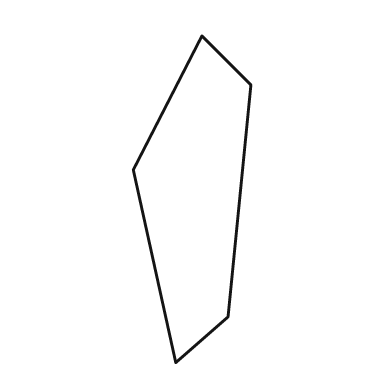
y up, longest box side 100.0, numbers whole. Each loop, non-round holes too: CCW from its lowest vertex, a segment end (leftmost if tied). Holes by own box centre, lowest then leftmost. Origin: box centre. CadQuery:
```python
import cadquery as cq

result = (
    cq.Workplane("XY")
    .moveTo(-5.0, -50.0)
    .lineTo(11.0, -36.0)
    .lineTo(18.0, 35.0)
    .lineTo(3.0, 50.0)
    .lineTo(-18.0, 9.0)
    .close()
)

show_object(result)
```